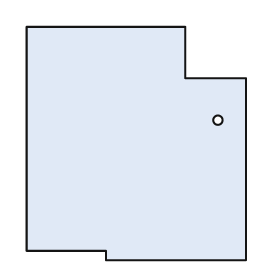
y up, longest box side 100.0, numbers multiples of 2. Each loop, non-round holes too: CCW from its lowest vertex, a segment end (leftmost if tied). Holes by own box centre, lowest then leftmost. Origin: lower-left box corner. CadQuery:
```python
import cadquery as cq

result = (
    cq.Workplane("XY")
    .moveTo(34.0, 0.0)
    .lineTo(94.0, 0.0)
    .lineTo(94.0, 78.0)
    .lineTo(68.0, 78.0)
    .lineTo(68.0, 100.0)
    .lineTo(0.0, 100.0)
    .lineTo(0.0, 4.0)
    .lineTo(34.0, 4.0)
    .close()
    .moveTo(82.0, 60.0)
    .circle(2.0)
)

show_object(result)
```